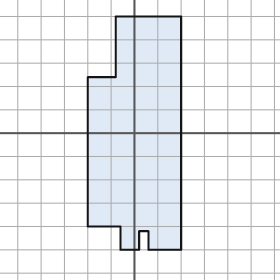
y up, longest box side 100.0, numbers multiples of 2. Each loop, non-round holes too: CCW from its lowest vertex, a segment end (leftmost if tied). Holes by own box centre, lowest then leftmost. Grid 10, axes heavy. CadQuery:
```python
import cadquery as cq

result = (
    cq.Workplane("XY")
    .moveTo(-6.0, -50.0)
    .lineTo(2.0, -50.0)
    .lineTo(2.0, -42.0)
    .lineTo(6.0, -42.0)
    .lineTo(6.0, -50.0)
    .lineTo(20.0, -50.0)
    .lineTo(20.0, 50.0)
    .lineTo(-8.0, 50.0)
    .lineTo(-8.0, 24.0)
    .lineTo(-20.0, 24.0)
    .lineTo(-20.0, -40.0)
    .lineTo(-6.0, -40.0)
    .close()
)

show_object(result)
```